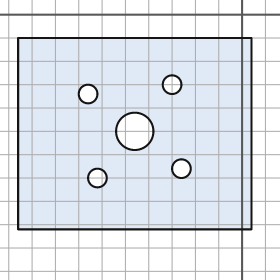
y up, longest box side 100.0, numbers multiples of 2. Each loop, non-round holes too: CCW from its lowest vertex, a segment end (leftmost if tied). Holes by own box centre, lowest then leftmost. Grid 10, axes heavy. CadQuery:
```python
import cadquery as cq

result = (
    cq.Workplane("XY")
    .moveTo(-96.0, -92.0)
    .lineTo(4.0, -92.0)
    .lineTo(4.0, -10.0)
    .lineTo(-96.0, -10.0)
    .close()
    .moveTo(-62.0, -70.0)
    .circle(4.0)
    .moveTo(-26.0, -66.0)
    .circle(4.0)
    .moveTo(-46.0, -50.0)
    .circle(8.0)
    .moveTo(-66.0, -34.0)
    .circle(4.0)
    .moveTo(-30.0, -30.0)
    .circle(4.0)
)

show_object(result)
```